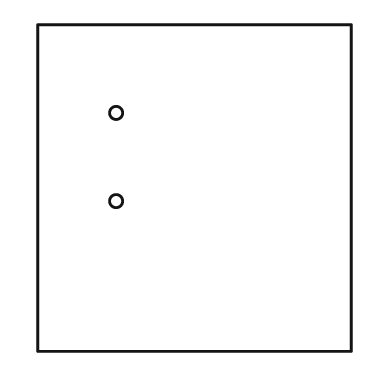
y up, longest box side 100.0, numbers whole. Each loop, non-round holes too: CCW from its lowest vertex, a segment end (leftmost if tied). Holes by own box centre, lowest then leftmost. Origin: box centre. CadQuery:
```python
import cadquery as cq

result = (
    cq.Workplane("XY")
    .moveTo(-48.0, -50.0)
    .lineTo(48.0, -50.0)
    .lineTo(48.0, 50.0)
    .lineTo(-48.0, 50.0)
    .close()
    .moveTo(-24.0, -4.0)
    .circle(2.0)
    .moveTo(-24.0, 23.0)
    .circle(2.0)
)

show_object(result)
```